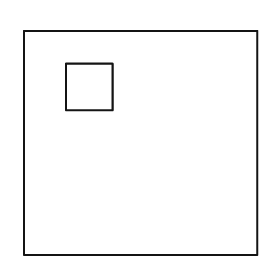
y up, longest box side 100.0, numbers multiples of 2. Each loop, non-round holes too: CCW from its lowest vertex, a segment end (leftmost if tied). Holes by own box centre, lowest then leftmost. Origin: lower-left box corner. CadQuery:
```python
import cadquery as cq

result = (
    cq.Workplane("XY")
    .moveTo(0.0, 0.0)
    .lineTo(100.0, 0.0)
    .lineTo(100.0, 96.0)
    .lineTo(0.0, 96.0)
    .close()
    .moveTo(18.0, 62.0)
    .lineTo(38.0, 62.0)
    .lineTo(38.0, 82.0)
    .lineTo(18.0, 82.0)
    .close()
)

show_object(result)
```